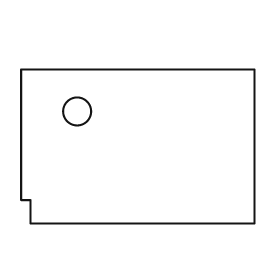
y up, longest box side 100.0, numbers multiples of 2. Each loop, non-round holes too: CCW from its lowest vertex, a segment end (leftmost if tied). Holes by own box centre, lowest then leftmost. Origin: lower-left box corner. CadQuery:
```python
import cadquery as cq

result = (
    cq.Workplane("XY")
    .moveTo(4.0, 0.0)
    .lineTo(100.0, 0.0)
    .lineTo(100.0, 66.0)
    .lineTo(0.0, 66.0)
    .lineTo(0.0, 10.0)
    .lineTo(4.0, 10.0)
    .close()
    .moveTo(24.0, 48.0)
    .circle(6.0)
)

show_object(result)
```